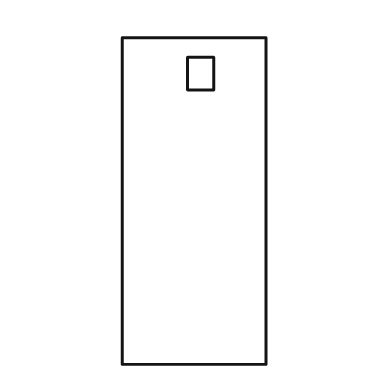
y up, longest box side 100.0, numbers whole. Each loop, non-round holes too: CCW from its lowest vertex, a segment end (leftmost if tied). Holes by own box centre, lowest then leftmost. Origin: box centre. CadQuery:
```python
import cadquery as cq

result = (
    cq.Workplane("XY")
    .moveTo(-22.0, -50.0)
    .lineTo(22.0, -50.0)
    .lineTo(22.0, 50.0)
    .lineTo(-22.0, 50.0)
    .close()
    .moveTo(-2.0, 34.0)
    .lineTo(6.0, 34.0)
    .lineTo(6.0, 44.0)
    .lineTo(-2.0, 44.0)
    .close()
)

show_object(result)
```